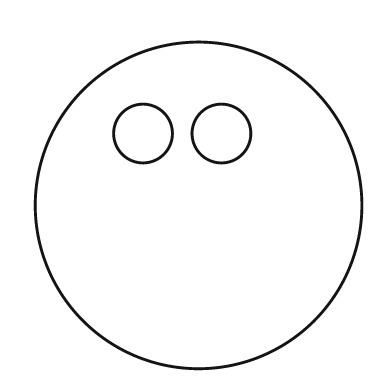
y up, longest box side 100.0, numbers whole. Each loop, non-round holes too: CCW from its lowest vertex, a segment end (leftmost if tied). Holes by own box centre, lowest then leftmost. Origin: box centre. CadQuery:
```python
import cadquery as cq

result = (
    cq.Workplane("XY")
    .moveTo(0.0, 0.0)
    .circle(50.0)
    .moveTo(-17.0, 22.0)
    .circle(9.0)
    .moveTo(7.0, 22.0)
    .circle(9.0)
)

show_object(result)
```